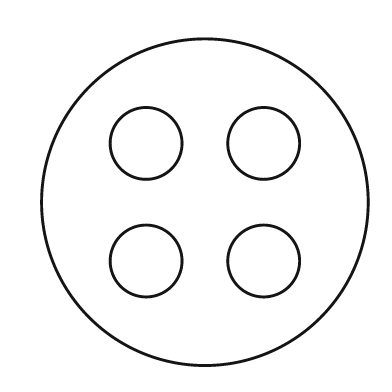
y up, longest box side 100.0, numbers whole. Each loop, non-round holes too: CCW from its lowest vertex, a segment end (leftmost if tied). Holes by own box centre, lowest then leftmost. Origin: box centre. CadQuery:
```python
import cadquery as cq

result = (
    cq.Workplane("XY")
    .moveTo(0.0, 0.0)
    .circle(50.0)
    .moveTo(-18.0, -18.0)
    .circle(11.0)
    .moveTo(18.0, -18.0)
    .circle(11.0)
    .moveTo(-18.0, 18.0)
    .circle(11.0)
    .moveTo(18.0, 18.0)
    .circle(11.0)
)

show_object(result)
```